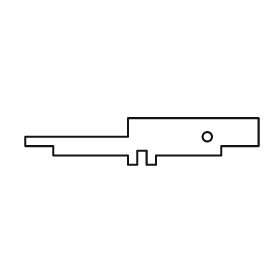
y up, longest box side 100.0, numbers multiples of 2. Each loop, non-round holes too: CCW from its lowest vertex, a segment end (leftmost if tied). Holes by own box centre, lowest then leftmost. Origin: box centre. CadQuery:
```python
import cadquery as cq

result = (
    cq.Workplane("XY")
    .moveTo(-6.0, -10.0)
    .lineTo(-2.0, -10.0)
    .lineTo(-2.0, -4.0)
    .lineTo(2.0, -4.0)
    .lineTo(2.0, -10.0)
    .lineTo(6.0, -10.0)
    .lineTo(6.0, -6.0)
    .lineTo(34.0, -6.0)
    .lineTo(34.0, -2.0)
    .lineTo(50.0, -2.0)
    .lineTo(50.0, 10.0)
    .lineTo(-6.0, 10.0)
    .lineTo(-6.0, 2.0)
    .lineTo(-50.0, 2.0)
    .lineTo(-50.0, -2.0)
    .lineTo(-38.0, -2.0)
    .lineTo(-38.0, -6.0)
    .lineTo(-6.0, -6.0)
    .close()
    .moveTo(28.0, 2.0)
    .circle(2.0)
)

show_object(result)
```